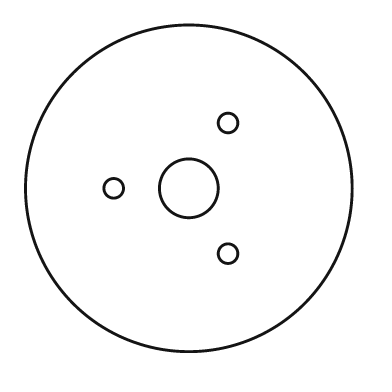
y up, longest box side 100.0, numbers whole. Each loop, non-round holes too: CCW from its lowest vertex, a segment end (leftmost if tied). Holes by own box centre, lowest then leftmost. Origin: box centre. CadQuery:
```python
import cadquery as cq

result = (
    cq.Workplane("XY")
    .moveTo(0.0, 0.0)
    .circle(50.0)
    .moveTo(12.0, -20.0)
    .circle(3.0)
    .moveTo(-23.0, 0.0)
    .circle(3.0)
    .moveTo(0.0, 0.0)
    .circle(9.0)
    .moveTo(12.0, 20.0)
    .circle(3.0)
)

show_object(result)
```